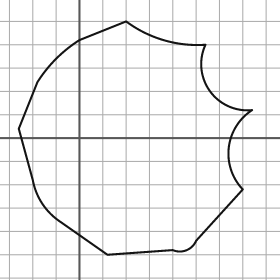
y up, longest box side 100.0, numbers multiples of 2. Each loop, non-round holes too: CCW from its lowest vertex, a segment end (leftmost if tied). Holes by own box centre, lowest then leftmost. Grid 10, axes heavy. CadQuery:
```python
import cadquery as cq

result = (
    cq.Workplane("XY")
    .moveTo(12.0, -50.0)
    .lineTo(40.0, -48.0)
    .threePointArc((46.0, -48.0), (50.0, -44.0))
    .lineTo(70.0, -22.0)
    .threePointArc((64.0, -4.0), (74.0, 12.0))
    .threePointArc((56.0, 20.0), (54.0, 40.0))
    .threePointArc((36.0, 42.0), (20.0, 50.0))
    .lineTo(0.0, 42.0)
    .threePointArc((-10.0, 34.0), (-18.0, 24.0))
    .lineTo(-26.0, 4.0)
    .lineTo(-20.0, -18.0)
    .threePointArc((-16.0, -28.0), (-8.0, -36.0))
    .close()
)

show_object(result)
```